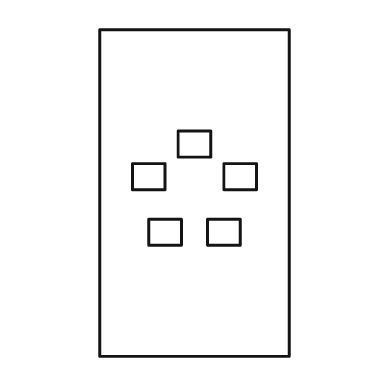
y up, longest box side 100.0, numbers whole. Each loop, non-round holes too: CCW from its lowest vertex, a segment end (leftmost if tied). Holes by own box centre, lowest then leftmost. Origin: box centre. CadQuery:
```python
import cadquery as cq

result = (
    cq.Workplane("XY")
    .moveTo(-29.0, -50.0)
    .lineTo(29.0, -50.0)
    .lineTo(29.0, 50.0)
    .lineTo(-29.0, 50.0)
    .close()
    .moveTo(-14.0, -16.0)
    .lineTo(-4.0, -16.0)
    .lineTo(-4.0, -8.0)
    .lineTo(-14.0, -8.0)
    .close()
    .moveTo(4.0, -16.0)
    .lineTo(14.0, -16.0)
    .lineTo(14.0, -8.0)
    .lineTo(4.0, -8.0)
    .close()
    .moveTo(-19.0, 1.0)
    .lineTo(-9.0, 1.0)
    .lineTo(-9.0, 9.0)
    .lineTo(-19.0, 9.0)
    .close()
    .moveTo(9.0, 1.0)
    .lineTo(19.0, 1.0)
    .lineTo(19.0, 9.0)
    .lineTo(9.0, 9.0)
    .close()
    .moveTo(-5.0, 11.0)
    .lineTo(5.0, 11.0)
    .lineTo(5.0, 19.0)
    .lineTo(-5.0, 19.0)
    .close()
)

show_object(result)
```